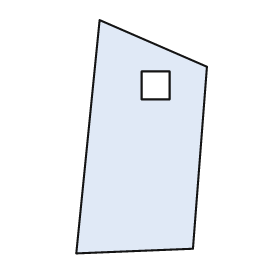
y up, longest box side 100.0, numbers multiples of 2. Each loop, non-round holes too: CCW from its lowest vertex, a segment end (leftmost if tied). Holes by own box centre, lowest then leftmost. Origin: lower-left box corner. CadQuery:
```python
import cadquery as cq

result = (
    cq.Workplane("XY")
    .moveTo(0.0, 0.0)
    .lineTo(50.0, 2.0)
    .lineTo(56.0, 80.0)
    .lineTo(10.0, 100.0)
    .close()
    .moveTo(28.0, 66.0)
    .lineTo(40.0, 66.0)
    .lineTo(40.0, 78.0)
    .lineTo(28.0, 78.0)
    .close()
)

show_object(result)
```